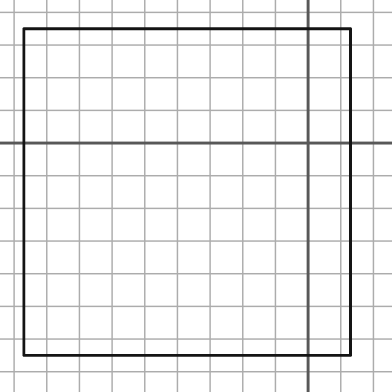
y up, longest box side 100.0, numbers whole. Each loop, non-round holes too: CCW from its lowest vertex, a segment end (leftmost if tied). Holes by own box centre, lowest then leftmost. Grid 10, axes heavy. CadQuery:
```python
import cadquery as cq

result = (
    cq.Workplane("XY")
    .moveTo(-87.0, -65.0)
    .lineTo(13.0, -65.0)
    .lineTo(13.0, 35.0)
    .lineTo(-87.0, 35.0)
    .close()
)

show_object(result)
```